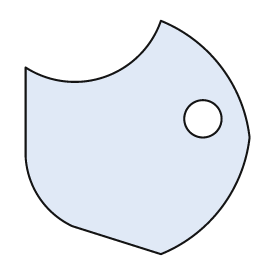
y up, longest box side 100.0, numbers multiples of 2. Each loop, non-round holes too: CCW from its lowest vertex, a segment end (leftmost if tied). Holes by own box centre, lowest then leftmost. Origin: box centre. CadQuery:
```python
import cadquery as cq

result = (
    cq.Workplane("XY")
    .moveTo(10.0, -50.0)
    .threePointArc((36.0, -30.0), (48.0, 0.0))
    .threePointArc((36.0, 30.0), (10.0, 50.0))
    .threePointArc((-14.0, 26.0), (-48.0, 30.0))
    .lineTo(-48.0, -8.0)
    .threePointArc((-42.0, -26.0), (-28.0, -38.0))
    .close()
    .moveTo(28.0, 8.0)
    .circle(8.0)
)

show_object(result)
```